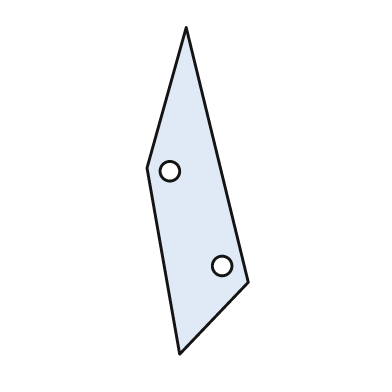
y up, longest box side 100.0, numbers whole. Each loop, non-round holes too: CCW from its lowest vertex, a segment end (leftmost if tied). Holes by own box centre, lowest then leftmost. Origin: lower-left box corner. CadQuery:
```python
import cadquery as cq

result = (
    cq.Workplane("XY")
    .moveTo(10.0, 0.0)
    .lineTo(31.0, 22.0)
    .lineTo(12.0, 100.0)
    .lineTo(0.0, 57.0)
    .close()
    .moveTo(23.0, 27.0)
    .circle(3.0)
    .moveTo(7.0, 56.0)
    .circle(3.0)
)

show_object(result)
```